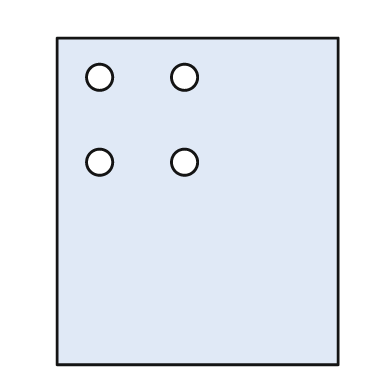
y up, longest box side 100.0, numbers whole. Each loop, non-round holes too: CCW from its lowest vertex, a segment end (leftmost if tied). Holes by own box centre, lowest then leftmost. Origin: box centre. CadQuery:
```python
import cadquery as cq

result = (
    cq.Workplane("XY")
    .moveTo(-43.0, -50.0)
    .lineTo(43.0, -50.0)
    .lineTo(43.0, 50.0)
    .lineTo(-43.0, 50.0)
    .close()
    .moveTo(-30.0, 12.0)
    .circle(4.0)
    .moveTo(-4.0, 12.0)
    .circle(4.0)
    .moveTo(-30.0, 38.0)
    .circle(4.0)
    .moveTo(-4.0, 38.0)
    .circle(4.0)
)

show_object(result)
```